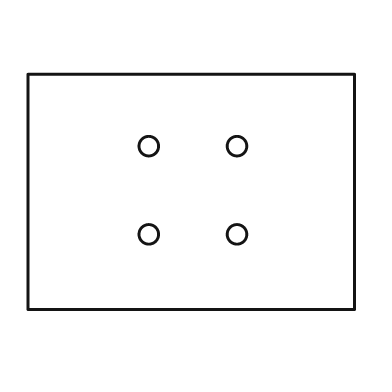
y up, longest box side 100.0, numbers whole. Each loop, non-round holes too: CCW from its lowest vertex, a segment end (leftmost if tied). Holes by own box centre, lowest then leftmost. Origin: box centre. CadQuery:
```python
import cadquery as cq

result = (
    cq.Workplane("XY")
    .moveTo(-50.0, -36.0)
    .lineTo(50.0, -36.0)
    .lineTo(50.0, 36.0)
    .lineTo(-50.0, 36.0)
    .close()
    .moveTo(-13.0, -13.0)
    .circle(3.0)
    .moveTo(14.0, -13.0)
    .circle(3.0)
    .moveTo(-13.0, 14.0)
    .circle(3.0)
    .moveTo(14.0, 14.0)
    .circle(3.0)
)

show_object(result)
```